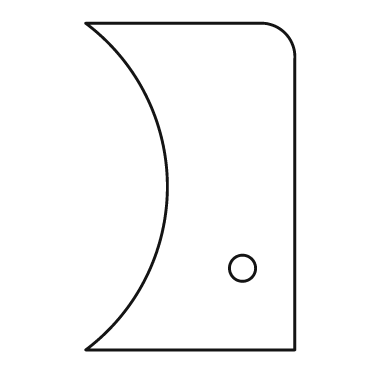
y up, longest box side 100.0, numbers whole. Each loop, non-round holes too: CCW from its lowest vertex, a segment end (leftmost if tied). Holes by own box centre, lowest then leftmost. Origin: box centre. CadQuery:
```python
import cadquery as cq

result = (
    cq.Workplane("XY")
    .moveTo(-32.0, -50.0)
    .lineTo(32.0, -50.0)
    .lineTo(32.0, 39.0)
    .threePointArc((29.0, 47.0), (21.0, 50.0))
    .lineTo(-32.0, 50.0)
    .threePointArc((-7.0, 0.0), (-32.0, -50.0))
    .close()
    .moveTo(16.0, -25.0)
    .circle(4.0)
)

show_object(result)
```